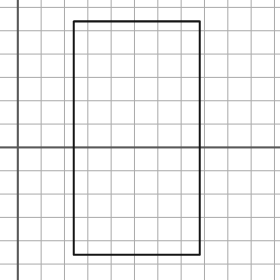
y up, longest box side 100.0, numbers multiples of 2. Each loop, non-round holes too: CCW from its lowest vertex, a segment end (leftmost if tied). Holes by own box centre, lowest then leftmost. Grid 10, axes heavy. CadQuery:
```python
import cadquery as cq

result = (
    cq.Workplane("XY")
    .moveTo(24.0, -46.0)
    .lineTo(78.0, -46.0)
    .lineTo(78.0, 54.0)
    .lineTo(24.0, 54.0)
    .close()
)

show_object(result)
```